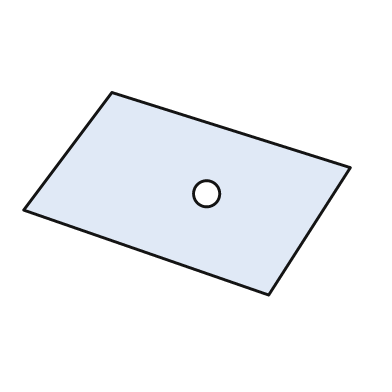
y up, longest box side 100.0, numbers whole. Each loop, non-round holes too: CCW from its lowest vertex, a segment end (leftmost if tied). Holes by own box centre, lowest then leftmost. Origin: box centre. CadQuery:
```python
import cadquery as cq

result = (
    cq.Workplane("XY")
    .moveTo(25.0, -31.0)
    .lineTo(50.0, 8.0)
    .lineTo(-23.0, 31.0)
    .lineTo(-50.0, -5.0)
    .close()
    .moveTo(6.0, 0.0)
    .circle(4.0)
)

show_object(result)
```